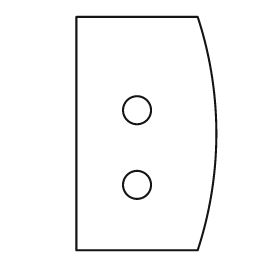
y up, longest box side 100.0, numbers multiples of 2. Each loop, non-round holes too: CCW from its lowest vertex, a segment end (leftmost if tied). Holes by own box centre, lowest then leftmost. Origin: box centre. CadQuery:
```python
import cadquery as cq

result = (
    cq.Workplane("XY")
    .moveTo(-30.0, -50.0)
    .lineTo(22.0, -50.0)
    .threePointArc((30.0, 0.0), (22.0, 50.0))
    .lineTo(-30.0, 50.0)
    .close()
    .moveTo(-4.0, -22.0)
    .circle(6.0)
    .moveTo(-4.0, 10.0)
    .circle(6.0)
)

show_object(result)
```